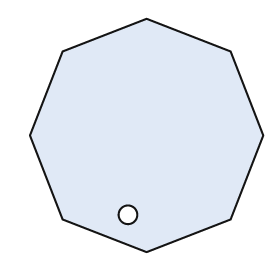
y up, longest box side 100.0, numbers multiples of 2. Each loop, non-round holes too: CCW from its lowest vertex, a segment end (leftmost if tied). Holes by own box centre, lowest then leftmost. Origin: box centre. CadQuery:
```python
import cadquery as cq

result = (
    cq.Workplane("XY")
    .moveTo(0.0, -50.0)
    .lineTo(36.0, -36.0)
    .lineTo(50.0, 0.0)
    .lineTo(36.0, 36.0)
    .lineTo(0.0, 50.0)
    .lineTo(-36.0, 36.0)
    .lineTo(-50.0, 0.0)
    .lineTo(-36.0, -36.0)
    .close()
    .moveTo(-8.0, -34.0)
    .circle(4.0)
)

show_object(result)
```